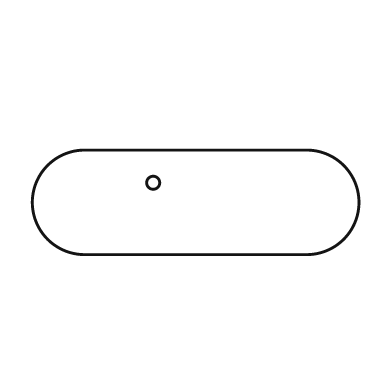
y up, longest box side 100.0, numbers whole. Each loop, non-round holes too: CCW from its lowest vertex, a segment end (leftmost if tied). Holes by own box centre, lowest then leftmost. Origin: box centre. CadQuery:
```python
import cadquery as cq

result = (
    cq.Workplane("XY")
    .moveTo(-34.0, -16.0)
    .lineTo(34.0, -16.0)
    .threePointArc((50.0, 0.0), (34.0, 16.0))
    .lineTo(-34.0, 16.0)
    .threePointArc((-50.0, 0.0), (-34.0, -16.0))
    .close()
    .moveTo(-13.0, 6.0)
    .circle(2.0)
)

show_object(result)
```